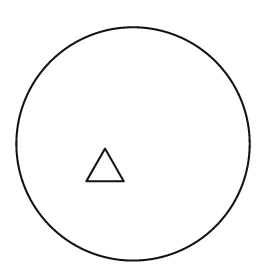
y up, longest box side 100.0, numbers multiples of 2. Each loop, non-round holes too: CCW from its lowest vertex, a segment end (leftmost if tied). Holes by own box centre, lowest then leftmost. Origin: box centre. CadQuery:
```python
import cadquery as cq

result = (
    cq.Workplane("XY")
    .moveTo(0.0, 0.0)
    .circle(50.0)
    .moveTo(-20.0, -16.0)
    .lineTo(-4.0, -16.0)
    .lineTo(-12.0, -2.0)
    .close()
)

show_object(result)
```